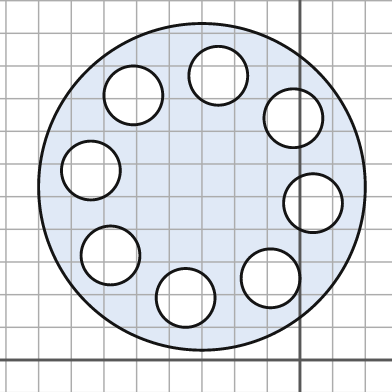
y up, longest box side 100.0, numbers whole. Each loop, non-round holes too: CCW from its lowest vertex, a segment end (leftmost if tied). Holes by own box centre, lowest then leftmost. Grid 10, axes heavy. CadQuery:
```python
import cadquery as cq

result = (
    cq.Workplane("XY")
    .moveTo(-30.0, 53.0)
    .circle(50.0)
    .moveTo(-35.0, 19.0)
    .circle(9.0)
    .moveTo(-9.0, 25.0)
    .circle(9.0)
    .moveTo(-58.0, 32.0)
    .circle(9.0)
    .moveTo(4.0, 48.0)
    .circle(9.0)
    .moveTo(-64.0, 58.0)
    .circle(9.0)
    .moveTo(-2.0, 74.0)
    .circle(9.0)
    .moveTo(-51.0, 81.0)
    .circle(9.0)
    .moveTo(-25.0, 87.0)
    .circle(9.0)
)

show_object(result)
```